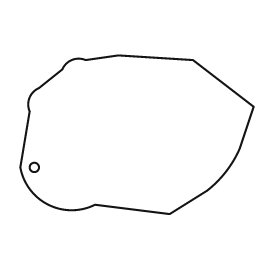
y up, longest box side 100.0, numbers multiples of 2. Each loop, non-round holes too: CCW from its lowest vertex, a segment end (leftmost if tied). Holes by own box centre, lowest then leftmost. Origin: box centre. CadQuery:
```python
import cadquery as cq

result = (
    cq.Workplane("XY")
    .moveTo(14.0, -34.0)
    .lineTo(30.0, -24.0)
    .threePointArc((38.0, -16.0), (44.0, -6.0))
    .lineTo(50.0, 12.0)
    .lineTo(24.0, 32.0)
    .lineTo(-8.0, 34.0)
    .lineTo(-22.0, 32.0)
    .threePointArc((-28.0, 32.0), (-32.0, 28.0))
    .lineTo(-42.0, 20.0)
    .threePointArc((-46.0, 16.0), (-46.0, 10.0))
    .lineTo(-50.0, -14.0)
    .threePointArc((-38.0, -30.0), (-18.0, -30.0))
    .close()
    .moveTo(-44.0, -14.0)
    .circle(2.0)
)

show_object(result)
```